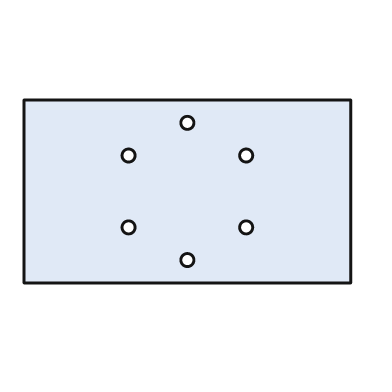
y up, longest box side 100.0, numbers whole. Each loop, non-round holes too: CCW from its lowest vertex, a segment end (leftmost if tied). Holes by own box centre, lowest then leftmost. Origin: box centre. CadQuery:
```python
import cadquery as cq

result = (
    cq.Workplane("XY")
    .moveTo(-50.0, -28.0)
    .lineTo(50.0, -28.0)
    .lineTo(50.0, 28.0)
    .lineTo(-50.0, 28.0)
    .close()
    .moveTo(0.0, -21.0)
    .circle(2.0)
    .moveTo(-18.0, -11.0)
    .circle(2.0)
    .moveTo(18.0, -11.0)
    .circle(2.0)
    .moveTo(-18.0, 11.0)
    .circle(2.0)
    .moveTo(18.0, 11.0)
    .circle(2.0)
    .moveTo(0.0, 21.0)
    .circle(2.0)
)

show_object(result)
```